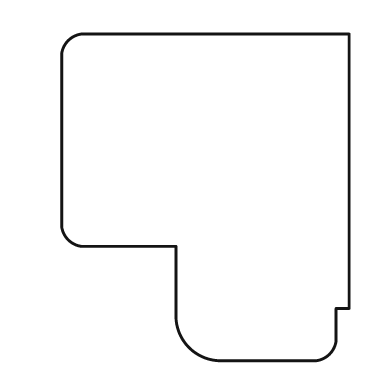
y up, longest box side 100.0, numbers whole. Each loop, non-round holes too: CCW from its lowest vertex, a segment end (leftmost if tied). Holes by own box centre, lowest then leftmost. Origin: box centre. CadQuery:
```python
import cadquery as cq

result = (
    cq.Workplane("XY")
    .moveTo(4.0, -50.0)
    .lineTo(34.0, -50.0)
    .threePointArc((38.0, -48.0), (40.0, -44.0))
    .lineTo(40.0, -34.0)
    .lineTo(44.0, -34.0)
    .lineTo(44.0, 50.0)
    .lineTo(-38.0, 50.0)
    .threePointArc((-42.0, 48.0), (-44.0, 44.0))
    .lineTo(-44.0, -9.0)
    .threePointArc((-42.0, -13.0), (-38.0, -15.0))
    .lineTo(-9.0, -15.0)
    .lineTo(-9.0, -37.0)
    .threePointArc((-5.0, -46.0), (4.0, -50.0))
    .close()
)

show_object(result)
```